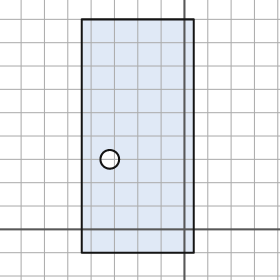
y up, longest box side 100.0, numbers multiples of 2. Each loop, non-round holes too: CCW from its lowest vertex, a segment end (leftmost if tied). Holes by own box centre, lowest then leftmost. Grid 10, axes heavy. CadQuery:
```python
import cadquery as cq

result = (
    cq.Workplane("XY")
    .moveTo(-44.0, -10.0)
    .lineTo(4.0, -10.0)
    .lineTo(4.0, 90.0)
    .lineTo(-44.0, 90.0)
    .close()
    .moveTo(-32.0, 30.0)
    .circle(4.0)
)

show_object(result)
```